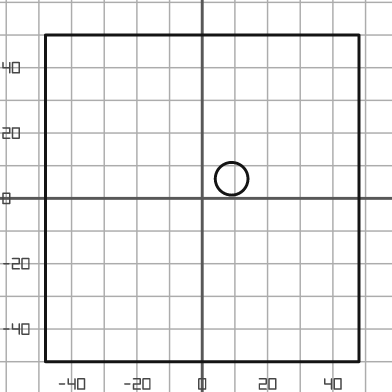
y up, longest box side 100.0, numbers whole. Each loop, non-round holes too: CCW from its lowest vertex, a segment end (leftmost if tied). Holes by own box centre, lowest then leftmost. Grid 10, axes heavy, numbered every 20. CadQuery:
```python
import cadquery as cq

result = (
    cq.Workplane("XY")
    .moveTo(-48.0, -50.0)
    .lineTo(48.0, -50.0)
    .lineTo(48.0, 50.0)
    .lineTo(-48.0, 50.0)
    .close()
    .moveTo(9.0, 6.0)
    .circle(5.0)
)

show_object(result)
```